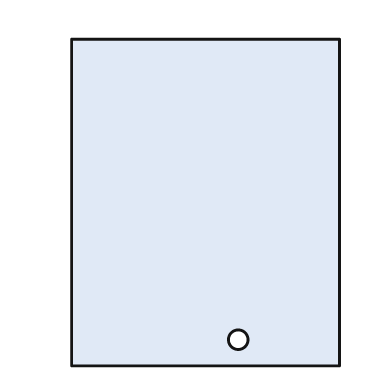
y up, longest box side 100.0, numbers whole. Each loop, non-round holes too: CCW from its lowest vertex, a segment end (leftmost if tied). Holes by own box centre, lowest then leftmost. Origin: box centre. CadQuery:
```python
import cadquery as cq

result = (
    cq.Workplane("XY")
    .moveTo(-41.0, -50.0)
    .lineTo(41.0, -50.0)
    .lineTo(41.0, 50.0)
    .lineTo(-41.0, 50.0)
    .close()
    .moveTo(10.0, -42.0)
    .circle(3.0)
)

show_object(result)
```